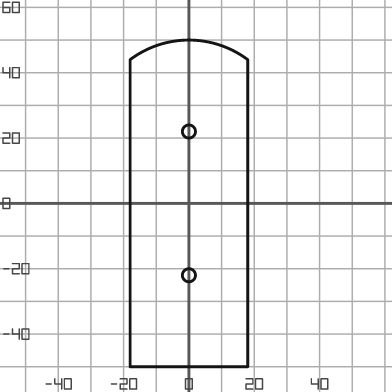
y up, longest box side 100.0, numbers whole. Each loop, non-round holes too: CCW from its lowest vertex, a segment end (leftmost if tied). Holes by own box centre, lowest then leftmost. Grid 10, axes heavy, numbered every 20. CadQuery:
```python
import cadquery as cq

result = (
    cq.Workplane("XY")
    .moveTo(-18.0, -50.0)
    .lineTo(18.0, -50.0)
    .lineTo(18.0, 44.0)
    .threePointArc((0.0, 50.0), (-18.0, 44.0))
    .close()
    .moveTo(0.0, -22.0)
    .circle(2.0)
    .moveTo(0.0, 22.0)
    .circle(2.0)
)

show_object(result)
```